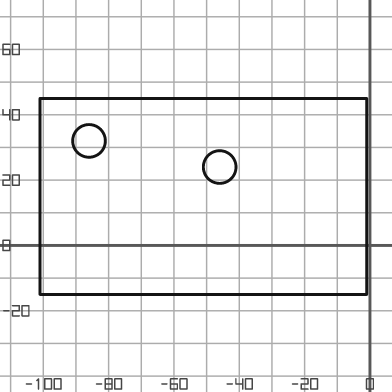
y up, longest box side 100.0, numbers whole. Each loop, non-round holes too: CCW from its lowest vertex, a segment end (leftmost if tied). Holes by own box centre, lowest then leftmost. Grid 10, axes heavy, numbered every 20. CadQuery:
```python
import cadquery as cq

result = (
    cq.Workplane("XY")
    .moveTo(-101.0, -15.0)
    .lineTo(-1.0, -15.0)
    .lineTo(-1.0, 45.0)
    .lineTo(-101.0, 45.0)
    .close()
    .moveTo(-46.0, 24.0)
    .circle(5.0)
    .moveTo(-86.0, 32.0)
    .circle(5.0)
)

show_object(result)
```